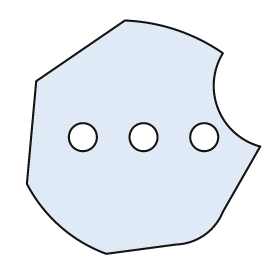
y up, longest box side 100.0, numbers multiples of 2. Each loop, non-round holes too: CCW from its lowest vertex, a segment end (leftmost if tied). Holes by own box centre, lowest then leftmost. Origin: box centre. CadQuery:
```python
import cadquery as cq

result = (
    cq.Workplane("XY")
    .moveTo(-16.0, -50.0)
    .lineTo(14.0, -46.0)
    .threePointArc((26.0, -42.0), (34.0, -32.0))
    .lineTo(50.0, -4.0)
    .threePointArc((32.0, 12.0), (34.0, 36.0))
    .threePointArc((14.0, 46.0), (-8.0, 50.0))
    .lineTo(-46.0, 24.0)
    .lineTo(-50.0, -20.0)
    .threePointArc((-36.0, -38.0), (-16.0, -50.0))
    .close()
    .moveTo(-26.0, 0.0)
    .circle(6.0)
    .moveTo(0.0, 0.0)
    .circle(6.0)
    .moveTo(26.0, 0.0)
    .circle(6.0)
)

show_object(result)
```